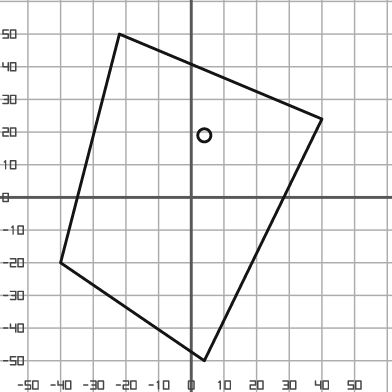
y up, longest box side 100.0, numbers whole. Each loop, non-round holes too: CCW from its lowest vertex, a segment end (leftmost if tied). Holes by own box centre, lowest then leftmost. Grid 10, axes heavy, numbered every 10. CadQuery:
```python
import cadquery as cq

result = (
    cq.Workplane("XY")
    .moveTo(4.0, -50.0)
    .lineTo(40.0, 24.0)
    .lineTo(-22.0, 50.0)
    .lineTo(-40.0, -20.0)
    .close()
    .moveTo(4.0, 19.0)
    .circle(2.0)
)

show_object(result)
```